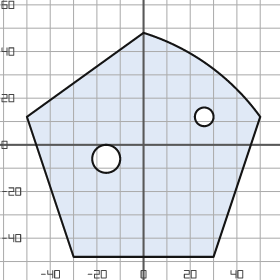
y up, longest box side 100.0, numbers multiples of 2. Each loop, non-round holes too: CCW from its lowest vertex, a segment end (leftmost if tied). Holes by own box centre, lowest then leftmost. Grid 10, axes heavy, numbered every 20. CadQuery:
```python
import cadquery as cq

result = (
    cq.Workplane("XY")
    .moveTo(-30.0, -48.0)
    .lineTo(30.0, -48.0)
    .lineTo(50.0, 12.0)
    .threePointArc((28.0, 34.0), (0.0, 48.0))
    .lineTo(-50.0, 12.0)
    .close()
    .moveTo(-16.0, -6.0)
    .circle(6.0)
    .moveTo(26.0, 12.0)
    .circle(4.0)
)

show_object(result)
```